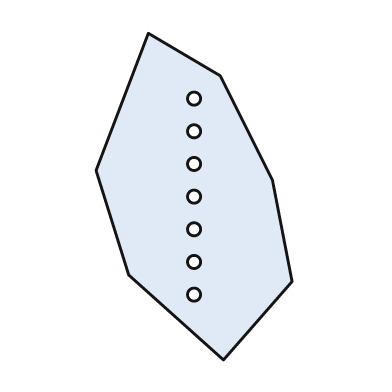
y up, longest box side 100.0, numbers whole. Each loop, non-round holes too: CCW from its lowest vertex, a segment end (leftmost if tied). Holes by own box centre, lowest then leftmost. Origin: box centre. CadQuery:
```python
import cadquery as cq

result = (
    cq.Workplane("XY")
    .moveTo(9.0, -50.0)
    .lineTo(30.0, -26.0)
    .lineTo(24.0, 5.0)
    .lineTo(8.0, 37.0)
    .lineTo(-14.0, 50.0)
    .lineTo(-30.0, 8.0)
    .lineTo(-20.0, -24.0)
    .close()
    .moveTo(0.0, -30.0)
    .circle(2.0)
    .moveTo(0.0, -20.0)
    .circle(2.0)
    .moveTo(0.0, -10.0)
    .circle(2.0)
    .moveTo(0.0, 0.0)
    .circle(2.0)
    .moveTo(0.0, 10.0)
    .circle(2.0)
    .moveTo(0.0, 20.0)
    .circle(2.0)
    .moveTo(0.0, 30.0)
    .circle(2.0)
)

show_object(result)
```